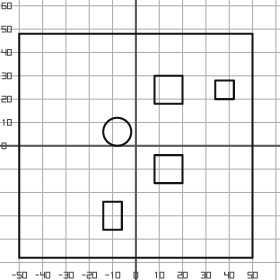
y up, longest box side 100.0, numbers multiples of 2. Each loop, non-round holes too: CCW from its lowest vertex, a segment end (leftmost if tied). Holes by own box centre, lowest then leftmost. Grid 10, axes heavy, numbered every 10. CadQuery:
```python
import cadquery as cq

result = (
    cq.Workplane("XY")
    .moveTo(-50.0, -48.0)
    .lineTo(50.0, -48.0)
    .lineTo(50.0, 48.0)
    .lineTo(-50.0, 48.0)
    .close()
    .moveTo(-14.0, -36.0)
    .lineTo(-6.0, -36.0)
    .lineTo(-6.0, -24.0)
    .lineTo(-14.0, -24.0)
    .close()
    .moveTo(8.0, -16.0)
    .lineTo(20.0, -16.0)
    .lineTo(20.0, -4.0)
    .lineTo(8.0, -4.0)
    .close()
    .moveTo(-8.0, 6.0)
    .circle(6.0)
    .moveTo(8.0, 18.0)
    .lineTo(20.0, 18.0)
    .lineTo(20.0, 30.0)
    .lineTo(8.0, 30.0)
    .close()
    .moveTo(34.0, 20.0)
    .lineTo(42.0, 20.0)
    .lineTo(42.0, 28.0)
    .lineTo(34.0, 28.0)
    .close()
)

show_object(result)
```